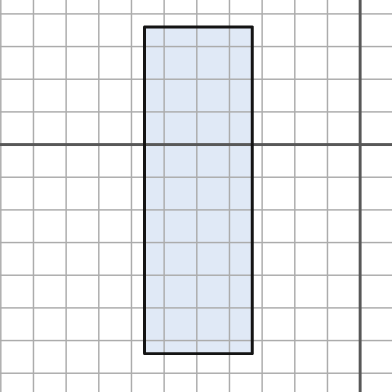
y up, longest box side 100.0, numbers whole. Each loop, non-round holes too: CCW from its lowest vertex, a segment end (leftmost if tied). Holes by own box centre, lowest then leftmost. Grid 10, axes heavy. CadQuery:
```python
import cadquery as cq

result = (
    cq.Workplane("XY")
    .moveTo(-66.0, -64.0)
    .lineTo(-33.0, -64.0)
    .lineTo(-33.0, 36.0)
    .lineTo(-66.0, 36.0)
    .close()
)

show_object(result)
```